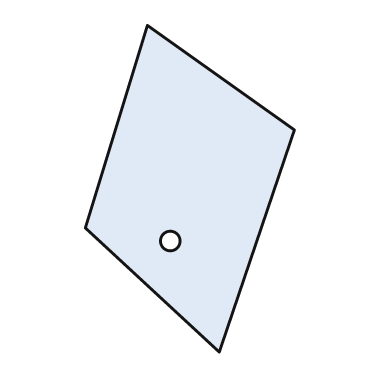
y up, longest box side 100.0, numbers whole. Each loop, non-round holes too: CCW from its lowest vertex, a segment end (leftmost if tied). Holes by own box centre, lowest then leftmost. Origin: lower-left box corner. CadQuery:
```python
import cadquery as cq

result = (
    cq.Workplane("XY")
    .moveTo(41.0, 0.0)
    .lineTo(64.0, 68.0)
    .lineTo(19.0, 100.0)
    .lineTo(0.0, 38.0)
    .close()
    .moveTo(26.0, 34.0)
    .circle(3.0)
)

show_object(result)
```